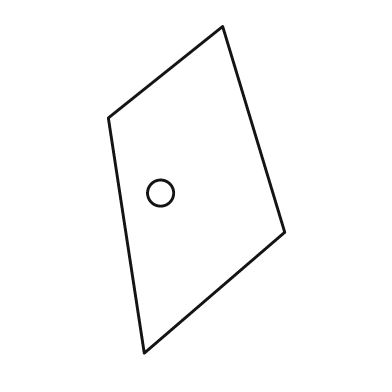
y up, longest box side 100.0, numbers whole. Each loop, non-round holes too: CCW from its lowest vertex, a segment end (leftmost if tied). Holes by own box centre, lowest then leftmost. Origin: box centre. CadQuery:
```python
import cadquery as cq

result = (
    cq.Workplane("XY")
    .moveTo(-16.0, -50.0)
    .lineTo(27.0, -13.0)
    .lineTo(8.0, 50.0)
    .lineTo(-27.0, 22.0)
    .close()
    .moveTo(-11.0, -1.0)
    .circle(4.0)
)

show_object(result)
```